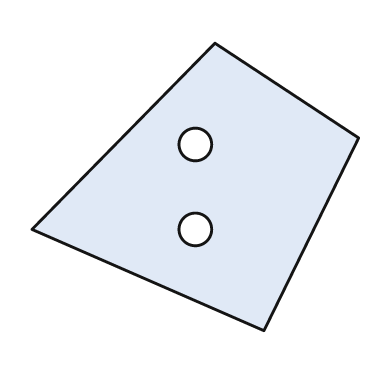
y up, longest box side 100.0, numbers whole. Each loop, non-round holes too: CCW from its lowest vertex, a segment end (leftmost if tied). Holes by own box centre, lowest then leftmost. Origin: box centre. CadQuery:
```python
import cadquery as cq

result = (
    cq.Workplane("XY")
    .moveTo(21.0, -44.0)
    .lineTo(50.0, 15.0)
    .lineTo(6.0, 44.0)
    .lineTo(-50.0, -13.0)
    .close()
    .moveTo(0.0, -13.0)
    .circle(5.0)
    .moveTo(0.0, 13.0)
    .circle(5.0)
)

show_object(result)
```